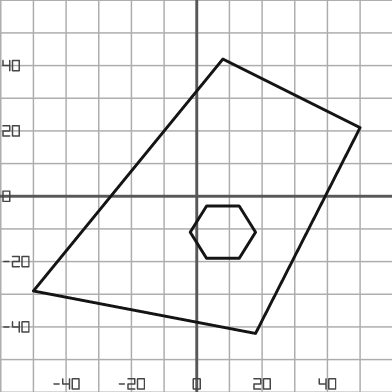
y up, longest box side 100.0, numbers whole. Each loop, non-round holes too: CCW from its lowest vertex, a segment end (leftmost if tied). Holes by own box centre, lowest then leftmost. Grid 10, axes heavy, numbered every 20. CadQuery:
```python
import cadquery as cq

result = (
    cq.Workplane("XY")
    .moveTo(18.0, -42.0)
    .lineTo(50.0, 21.0)
    .lineTo(8.0, 42.0)
    .lineTo(-50.0, -29.0)
    .close()
    .moveTo(3.0, -19.0)
    .lineTo(13.0, -19.0)
    .lineTo(18.0, -11.0)
    .lineTo(13.0, -3.0)
    .lineTo(3.0, -3.0)
    .lineTo(-2.0, -11.0)
    .close()
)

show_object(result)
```